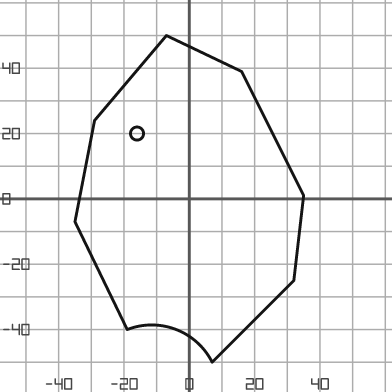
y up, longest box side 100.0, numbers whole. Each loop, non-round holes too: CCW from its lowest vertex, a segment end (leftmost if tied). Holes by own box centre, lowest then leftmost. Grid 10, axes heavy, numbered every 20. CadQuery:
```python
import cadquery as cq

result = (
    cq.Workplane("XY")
    .moveTo(7.0, -50.0)
    .lineTo(32.0, -25.0)
    .lineTo(35.0, 1.0)
    .lineTo(16.0, 39.0)
    .lineTo(-7.0, 50.0)
    .lineTo(-29.0, 24.0)
    .lineTo(-35.0, -7.0)
    .lineTo(-19.0, -40.0)
    .threePointArc((-4.0, -40.0), (7.0, -50.0))
    .close()
    .moveTo(-16.0, 20.0)
    .circle(2.0)
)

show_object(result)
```